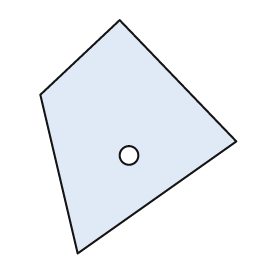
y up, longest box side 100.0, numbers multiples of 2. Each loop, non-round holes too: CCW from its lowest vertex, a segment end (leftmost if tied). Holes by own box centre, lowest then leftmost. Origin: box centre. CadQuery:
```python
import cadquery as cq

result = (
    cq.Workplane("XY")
    .moveTo(-26.0, -50.0)
    .lineTo(42.0, -2.0)
    .lineTo(-8.0, 50.0)
    .lineTo(-42.0, 18.0)
    .close()
    .moveTo(-4.0, -8.0)
    .circle(4.0)
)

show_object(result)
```